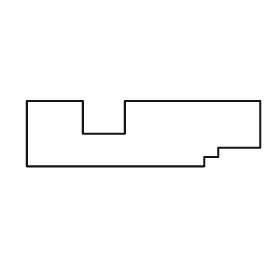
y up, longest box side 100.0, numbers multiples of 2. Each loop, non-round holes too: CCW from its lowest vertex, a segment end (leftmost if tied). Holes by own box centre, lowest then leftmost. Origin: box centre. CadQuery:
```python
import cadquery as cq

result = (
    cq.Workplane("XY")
    .moveTo(-50.0, -14.0)
    .lineTo(26.0, -14.0)
    .lineTo(26.0, -10.0)
    .lineTo(32.0, -10.0)
    .lineTo(32.0, -6.0)
    .lineTo(50.0, -6.0)
    .lineTo(50.0, 14.0)
    .lineTo(-8.0, 14.0)
    .lineTo(-8.0, 0.0)
    .lineTo(-26.0, 0.0)
    .lineTo(-26.0, 14.0)
    .lineTo(-50.0, 14.0)
    .close()
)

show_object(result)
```